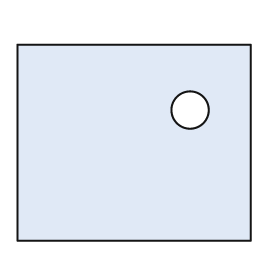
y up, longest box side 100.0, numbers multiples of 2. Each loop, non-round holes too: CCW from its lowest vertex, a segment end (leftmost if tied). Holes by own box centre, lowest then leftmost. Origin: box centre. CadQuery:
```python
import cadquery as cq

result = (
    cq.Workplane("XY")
    .moveTo(-50.0, -42.0)
    .lineTo(50.0, -42.0)
    .lineTo(50.0, 42.0)
    .lineTo(-50.0, 42.0)
    .close()
    .moveTo(24.0, 14.0)
    .circle(8.0)
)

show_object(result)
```